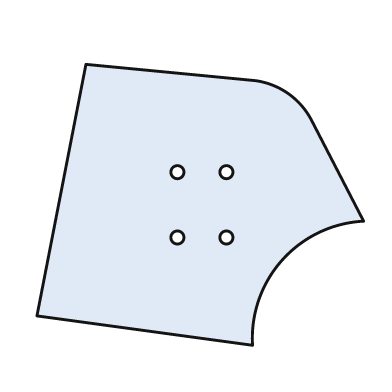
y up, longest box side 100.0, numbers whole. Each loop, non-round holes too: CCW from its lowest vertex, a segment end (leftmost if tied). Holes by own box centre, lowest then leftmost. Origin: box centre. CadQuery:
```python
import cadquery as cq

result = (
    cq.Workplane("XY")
    .moveTo(16.0, -43.0)
    .threePointArc((25.0, -17.0), (50.0, -5.0))
    .lineTo(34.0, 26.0)
    .threePointArc((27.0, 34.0), (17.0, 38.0))
    .lineTo(-35.0, 43.0)
    .lineTo(-50.0, -34.0)
    .close()
    .moveTo(-7.0, -10.0)
    .circle(2.0)
    .moveTo(8.0, -10.0)
    .circle(2.0)
    .moveTo(-7.0, 10.0)
    .circle(2.0)
    .moveTo(8.0, 10.0)
    .circle(2.0)
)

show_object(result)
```